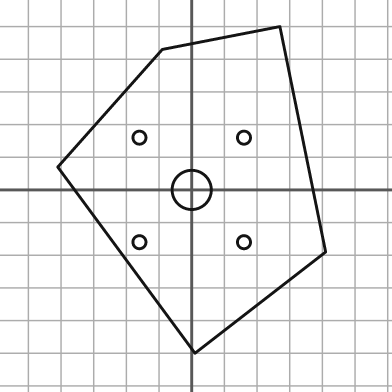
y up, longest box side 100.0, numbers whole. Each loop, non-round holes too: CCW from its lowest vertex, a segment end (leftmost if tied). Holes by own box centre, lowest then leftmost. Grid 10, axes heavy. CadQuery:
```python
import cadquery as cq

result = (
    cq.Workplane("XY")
    .moveTo(1.0, -50.0)
    .lineTo(41.0, -19.0)
    .lineTo(27.0, 50.0)
    .lineTo(-9.0, 43.0)
    .lineTo(-41.0, 7.0)
    .close()
    .moveTo(-16.0, -16.0)
    .circle(2.0)
    .moveTo(16.0, -16.0)
    .circle(2.0)
    .moveTo(0.0, 0.0)
    .circle(6.0)
    .moveTo(-16.0, 16.0)
    .circle(2.0)
    .moveTo(16.0, 16.0)
    .circle(2.0)
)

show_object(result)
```